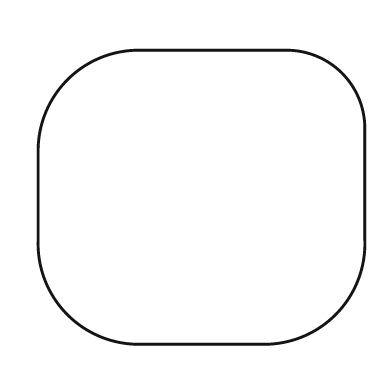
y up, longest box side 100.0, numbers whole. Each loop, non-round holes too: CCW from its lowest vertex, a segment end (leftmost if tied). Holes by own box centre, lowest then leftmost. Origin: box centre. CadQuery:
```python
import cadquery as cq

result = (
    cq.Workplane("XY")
    .moveTo(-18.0, -45.0)
    .lineTo(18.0, -45.0)
    .threePointArc((41.0, -36.0), (50.0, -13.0))
    .lineTo(50.0, 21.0)
    .threePointArc((43.0, 38.0), (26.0, 45.0))
    .lineTo(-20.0, 45.0)
    .threePointArc((-41.0, 36.0), (-50.0, 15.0))
    .lineTo(-50.0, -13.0)
    .threePointArc((-41.0, -36.0), (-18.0, -45.0))
    .close()
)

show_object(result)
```